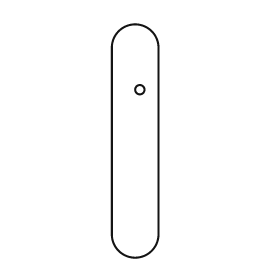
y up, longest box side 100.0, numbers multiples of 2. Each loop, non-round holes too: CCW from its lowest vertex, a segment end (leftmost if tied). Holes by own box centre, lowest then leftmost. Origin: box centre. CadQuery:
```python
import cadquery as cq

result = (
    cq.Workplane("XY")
    .moveTo(-10.0, -40.0)
    .threePointArc((0.0, -50.0), (10.0, -40.0))
    .lineTo(10.0, 40.0)
    .threePointArc((0.0, 50.0), (-10.0, 40.0))
    .close()
    .moveTo(2.0, 22.0)
    .circle(2.0)
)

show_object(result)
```